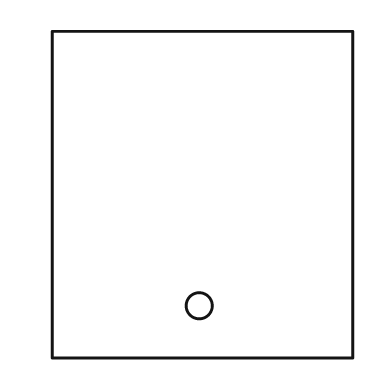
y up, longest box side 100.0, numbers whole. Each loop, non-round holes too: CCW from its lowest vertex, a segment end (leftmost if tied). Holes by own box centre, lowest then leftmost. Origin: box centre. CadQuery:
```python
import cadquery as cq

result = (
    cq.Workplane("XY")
    .moveTo(-46.0, -50.0)
    .lineTo(46.0, -50.0)
    .lineTo(46.0, 50.0)
    .lineTo(-46.0, 50.0)
    .close()
    .moveTo(-1.0, -34.0)
    .circle(4.0)
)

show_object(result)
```